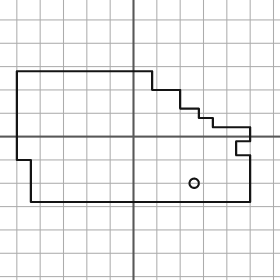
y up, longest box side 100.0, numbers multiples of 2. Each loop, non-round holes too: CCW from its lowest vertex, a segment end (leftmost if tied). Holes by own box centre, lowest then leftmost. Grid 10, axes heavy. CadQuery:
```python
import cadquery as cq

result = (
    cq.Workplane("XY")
    .moveTo(-44.0, -28.0)
    .lineTo(50.0, -28.0)
    .lineTo(50.0, -8.0)
    .lineTo(44.0, -8.0)
    .lineTo(44.0, -2.0)
    .lineTo(50.0, -2.0)
    .lineTo(50.0, 4.0)
    .lineTo(34.0, 4.0)
    .lineTo(34.0, 8.0)
    .lineTo(28.0, 8.0)
    .lineTo(28.0, 12.0)
    .lineTo(20.0, 12.0)
    .lineTo(20.0, 20.0)
    .lineTo(8.0, 20.0)
    .lineTo(8.0, 28.0)
    .lineTo(-50.0, 28.0)
    .lineTo(-50.0, -10.0)
    .lineTo(-44.0, -10.0)
    .close()
    .moveTo(26.0, -20.0)
    .circle(2.0)
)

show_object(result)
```